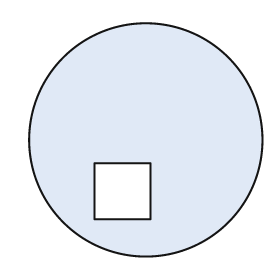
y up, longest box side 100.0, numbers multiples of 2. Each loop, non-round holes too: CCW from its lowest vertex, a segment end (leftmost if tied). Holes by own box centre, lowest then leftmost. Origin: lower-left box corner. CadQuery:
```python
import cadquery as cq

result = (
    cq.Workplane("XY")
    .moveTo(50.0, 50.0)
    .circle(50.0)
    .moveTo(28.0, 16.0)
    .lineTo(52.0, 16.0)
    .lineTo(52.0, 40.0)
    .lineTo(28.0, 40.0)
    .close()
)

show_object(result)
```